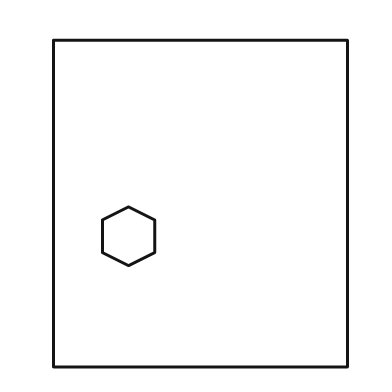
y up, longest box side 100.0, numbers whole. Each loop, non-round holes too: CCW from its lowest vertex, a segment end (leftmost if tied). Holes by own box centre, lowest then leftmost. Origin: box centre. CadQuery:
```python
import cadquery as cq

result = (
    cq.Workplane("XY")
    .moveTo(-45.0, -50.0)
    .lineTo(45.0, -50.0)
    .lineTo(45.0, 50.0)
    .lineTo(-45.0, 50.0)
    .close()
    .moveTo(-22.0, -19.0)
    .lineTo(-14.0, -15.0)
    .lineTo(-14.0, -5.0)
    .lineTo(-22.0, -1.0)
    .lineTo(-30.0, -5.0)
    .lineTo(-30.0, -15.0)
    .close()
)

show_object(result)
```